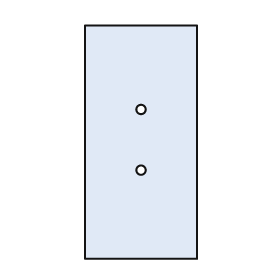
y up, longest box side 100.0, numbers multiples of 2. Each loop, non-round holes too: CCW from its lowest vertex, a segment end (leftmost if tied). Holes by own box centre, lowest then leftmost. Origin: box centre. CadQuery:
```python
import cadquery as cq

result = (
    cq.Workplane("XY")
    .moveTo(-24.0, -50.0)
    .lineTo(24.0, -50.0)
    .lineTo(24.0, 50.0)
    .lineTo(-24.0, 50.0)
    .close()
    .moveTo(0.0, -12.0)
    .circle(2.0)
    .moveTo(0.0, 14.0)
    .circle(2.0)
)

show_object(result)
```